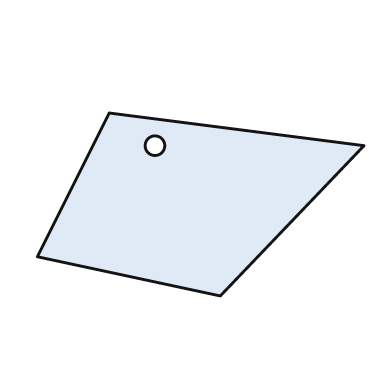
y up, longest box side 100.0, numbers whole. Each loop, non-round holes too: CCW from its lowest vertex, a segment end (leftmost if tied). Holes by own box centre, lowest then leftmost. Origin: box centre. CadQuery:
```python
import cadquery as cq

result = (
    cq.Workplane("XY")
    .moveTo(6.0, -28.0)
    .lineTo(50.0, 18.0)
    .lineTo(-28.0, 28.0)
    .lineTo(-50.0, -16.0)
    .close()
    .moveTo(-14.0, 18.0)
    .circle(3.0)
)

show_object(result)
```